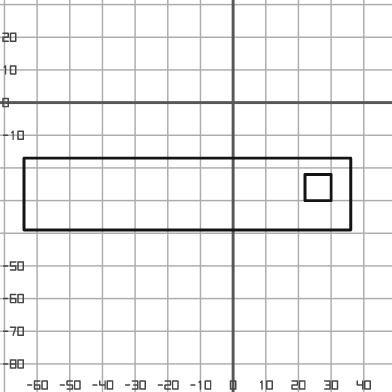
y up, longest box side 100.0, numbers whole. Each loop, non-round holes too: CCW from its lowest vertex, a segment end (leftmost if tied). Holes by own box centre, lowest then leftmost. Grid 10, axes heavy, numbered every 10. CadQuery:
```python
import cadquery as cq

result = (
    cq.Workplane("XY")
    .moveTo(-64.0, -39.0)
    .lineTo(36.0, -39.0)
    .lineTo(36.0, -17.0)
    .lineTo(-64.0, -17.0)
    .close()
    .moveTo(22.0, -30.0)
    .lineTo(30.0, -30.0)
    .lineTo(30.0, -22.0)
    .lineTo(22.0, -22.0)
    .close()
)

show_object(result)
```